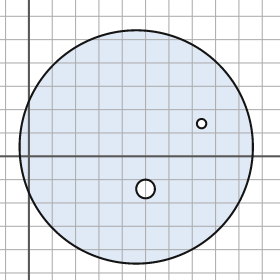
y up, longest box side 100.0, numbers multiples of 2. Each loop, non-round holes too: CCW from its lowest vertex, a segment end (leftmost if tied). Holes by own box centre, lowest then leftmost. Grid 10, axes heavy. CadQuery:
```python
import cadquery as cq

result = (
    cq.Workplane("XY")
    .moveTo(46.0, 4.0)
    .circle(50.0)
    .moveTo(50.0, -14.0)
    .circle(4.0)
    .moveTo(74.0, 14.0)
    .circle(2.0)
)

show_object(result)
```